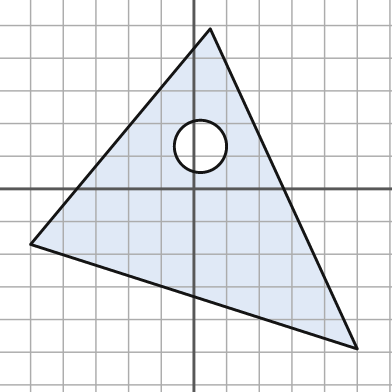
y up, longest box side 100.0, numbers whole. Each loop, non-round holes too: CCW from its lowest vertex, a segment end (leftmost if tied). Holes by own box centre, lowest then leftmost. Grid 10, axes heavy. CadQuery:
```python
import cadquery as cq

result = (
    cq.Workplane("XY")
    .moveTo(50.0, -49.0)
    .lineTo(5.0, 49.0)
    .lineTo(-50.0, -17.0)
    .close()
    .moveTo(2.0, 13.0)
    .circle(8.0)
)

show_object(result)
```